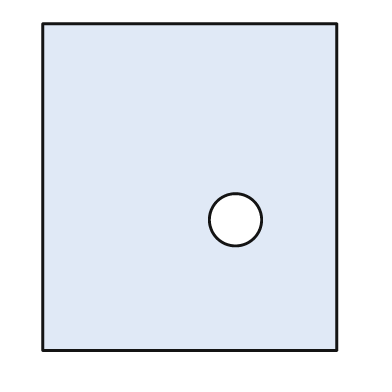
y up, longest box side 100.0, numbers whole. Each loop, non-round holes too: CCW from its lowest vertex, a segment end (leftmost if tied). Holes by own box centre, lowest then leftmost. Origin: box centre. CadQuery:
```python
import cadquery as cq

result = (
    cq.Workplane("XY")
    .moveTo(-45.0, -50.0)
    .lineTo(45.0, -50.0)
    .lineTo(45.0, 50.0)
    .lineTo(-45.0, 50.0)
    .close()
    .moveTo(14.0, -10.0)
    .circle(8.0)
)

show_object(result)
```